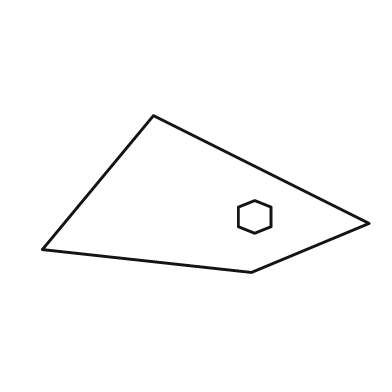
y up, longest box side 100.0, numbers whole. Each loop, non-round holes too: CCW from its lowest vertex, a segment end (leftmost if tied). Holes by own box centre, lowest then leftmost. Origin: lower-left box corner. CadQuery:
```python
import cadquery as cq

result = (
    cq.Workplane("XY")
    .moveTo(64.0, 0.0)
    .lineTo(100.0, 15.0)
    .lineTo(34.0, 48.0)
    .lineTo(0.0, 7.0)
    .close()
    .moveTo(65.0, 12.0)
    .lineTo(70.0, 14.0)
    .lineTo(70.0, 20.0)
    .lineTo(65.0, 22.0)
    .lineTo(60.0, 20.0)
    .lineTo(60.0, 14.0)
    .close()
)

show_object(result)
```